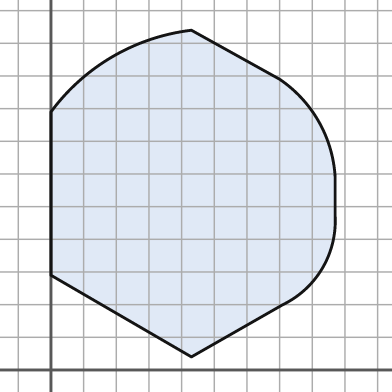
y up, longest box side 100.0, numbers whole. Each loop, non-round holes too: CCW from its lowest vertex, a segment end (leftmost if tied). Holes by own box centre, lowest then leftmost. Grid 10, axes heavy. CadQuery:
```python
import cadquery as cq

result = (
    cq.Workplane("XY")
    .moveTo(43.0, 4.0)
    .lineTo(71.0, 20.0)
    .threePointArc((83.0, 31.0), (87.0, 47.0))
    .lineTo(87.0, 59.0)
    .threePointArc((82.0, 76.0), (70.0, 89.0))
    .lineTo(43.0, 104.0)
    .threePointArc((19.0, 96.0), (0.0, 79.0))
    .lineTo(0.0, 29.0)
    .close()
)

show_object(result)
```